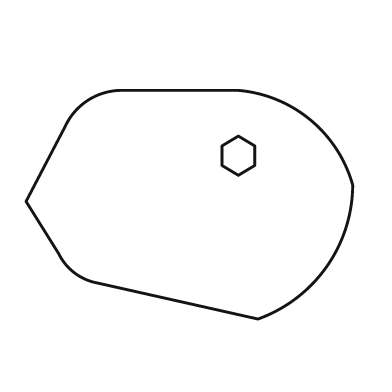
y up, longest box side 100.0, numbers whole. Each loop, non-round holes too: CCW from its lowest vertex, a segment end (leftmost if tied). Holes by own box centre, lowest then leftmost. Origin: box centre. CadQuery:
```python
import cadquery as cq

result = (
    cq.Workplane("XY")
    .moveTo(21.0, -35.0)
    .threePointArc((42.0, -19.0), (50.0, 6.0))
    .threePointArc((37.0, 26.0), (15.0, 35.0))
    .lineTo(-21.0, 35.0)
    .threePointArc((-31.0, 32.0), (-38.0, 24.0))
    .lineTo(-50.0, 1.0)
    .lineTo(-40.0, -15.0)
    .threePointArc((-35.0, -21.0), (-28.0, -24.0))
    .close()
    .moveTo(15.0, 9.0)
    .lineTo(20.0, 12.0)
    .lineTo(20.0, 18.0)
    .lineTo(15.0, 21.0)
    .lineTo(10.0, 18.0)
    .lineTo(10.0, 12.0)
    .close()
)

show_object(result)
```